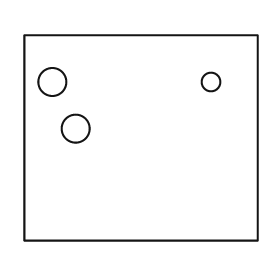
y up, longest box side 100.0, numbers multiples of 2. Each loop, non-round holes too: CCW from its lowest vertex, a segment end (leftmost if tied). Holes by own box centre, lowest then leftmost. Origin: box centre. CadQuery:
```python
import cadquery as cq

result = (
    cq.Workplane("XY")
    .moveTo(-50.0, -44.0)
    .lineTo(50.0, -44.0)
    .lineTo(50.0, 44.0)
    .lineTo(-50.0, 44.0)
    .close()
    .moveTo(-28.0, 4.0)
    .circle(6.0)
    .moveTo(-38.0, 24.0)
    .circle(6.0)
    .moveTo(30.0, 24.0)
    .circle(4.0)
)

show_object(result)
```